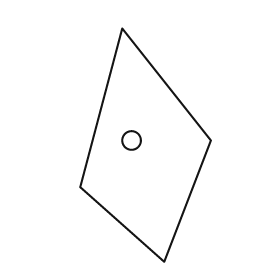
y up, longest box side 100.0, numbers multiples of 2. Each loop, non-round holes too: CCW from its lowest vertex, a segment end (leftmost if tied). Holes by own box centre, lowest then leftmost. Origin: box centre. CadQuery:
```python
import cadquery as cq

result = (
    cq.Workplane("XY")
    .moveTo(8.0, -50.0)
    .lineTo(28.0, 2.0)
    .lineTo(-10.0, 50.0)
    .lineTo(-28.0, -18.0)
    .close()
    .moveTo(-6.0, 2.0)
    .circle(4.0)
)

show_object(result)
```